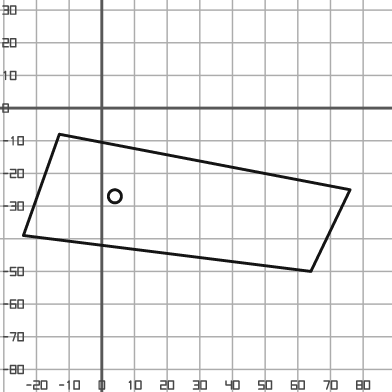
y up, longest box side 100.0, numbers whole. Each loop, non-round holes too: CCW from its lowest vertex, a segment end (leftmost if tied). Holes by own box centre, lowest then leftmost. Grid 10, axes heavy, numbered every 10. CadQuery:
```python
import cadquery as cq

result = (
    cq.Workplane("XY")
    .moveTo(64.0, -50.0)
    .lineTo(76.0, -25.0)
    .lineTo(-13.0, -8.0)
    .lineTo(-24.0, -39.0)
    .close()
    .moveTo(4.0, -27.0)
    .circle(2.0)
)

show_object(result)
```